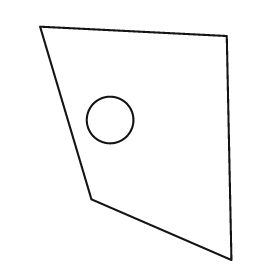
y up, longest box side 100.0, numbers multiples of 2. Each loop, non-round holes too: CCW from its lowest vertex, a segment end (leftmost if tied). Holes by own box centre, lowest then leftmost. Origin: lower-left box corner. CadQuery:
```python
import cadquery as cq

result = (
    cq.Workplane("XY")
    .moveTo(82.0, 0.0)
    .lineTo(80.0, 96.0)
    .lineTo(0.0, 100.0)
    .lineTo(22.0, 26.0)
    .close()
    .moveTo(30.0, 60.0)
    .circle(10.0)
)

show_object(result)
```